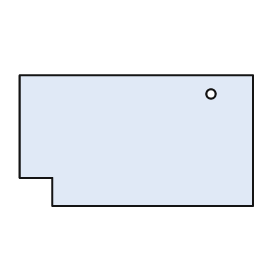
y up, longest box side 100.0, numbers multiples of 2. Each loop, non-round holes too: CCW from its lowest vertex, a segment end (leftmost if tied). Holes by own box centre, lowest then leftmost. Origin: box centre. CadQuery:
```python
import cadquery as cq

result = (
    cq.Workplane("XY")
    .moveTo(-36.0, -28.0)
    .lineTo(50.0, -28.0)
    .lineTo(50.0, 28.0)
    .lineTo(-50.0, 28.0)
    .lineTo(-50.0, -16.0)
    .lineTo(-36.0, -16.0)
    .close()
    .moveTo(32.0, 20.0)
    .circle(2.0)
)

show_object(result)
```